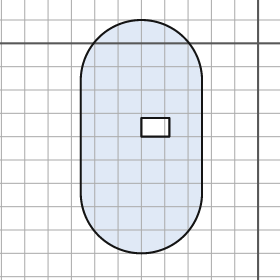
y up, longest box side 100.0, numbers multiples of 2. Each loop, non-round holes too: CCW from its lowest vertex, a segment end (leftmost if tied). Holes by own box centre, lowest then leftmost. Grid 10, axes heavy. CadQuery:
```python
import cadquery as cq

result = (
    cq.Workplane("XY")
    .moveTo(-76.0, -64.0)
    .threePointArc((-50.0, -90.0), (-24.0, -64.0))
    .lineTo(-24.0, -16.0)
    .threePointArc((-50.0, 10.0), (-76.0, -16.0))
    .close()
    .moveTo(-50.0, -40.0)
    .lineTo(-38.0, -40.0)
    .lineTo(-38.0, -32.0)
    .lineTo(-50.0, -32.0)
    .close()
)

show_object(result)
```